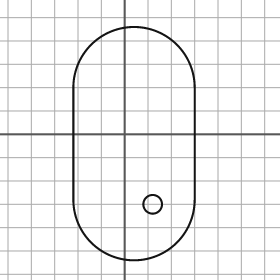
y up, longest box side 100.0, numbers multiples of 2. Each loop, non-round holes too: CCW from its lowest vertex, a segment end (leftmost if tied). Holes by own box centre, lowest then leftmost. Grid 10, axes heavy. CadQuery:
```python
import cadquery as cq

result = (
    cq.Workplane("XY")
    .moveTo(-22.0, -28.0)
    .threePointArc((4.0, -54.0), (30.0, -28.0))
    .lineTo(30.0, 20.0)
    .threePointArc((4.0, 46.0), (-22.0, 20.0))
    .close()
    .moveTo(12.0, -30.0)
    .circle(4.0)
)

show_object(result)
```